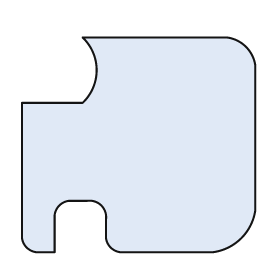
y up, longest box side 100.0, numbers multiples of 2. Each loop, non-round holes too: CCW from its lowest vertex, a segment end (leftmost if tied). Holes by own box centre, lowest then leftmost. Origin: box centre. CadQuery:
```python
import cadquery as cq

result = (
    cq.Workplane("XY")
    .moveTo(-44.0, -46.0)
    .lineTo(-36.0, -46.0)
    .lineTo(-36.0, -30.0)
    .threePointArc((-34.0, -26.0), (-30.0, -24.0))
    .lineTo(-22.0, -24.0)
    .threePointArc((-16.0, -26.0), (-14.0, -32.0))
    .lineTo(-14.0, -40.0)
    .threePointArc((-12.0, -44.0), (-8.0, -46.0))
    .lineTo(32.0, -46.0)
    .threePointArc((44.0, -40.0), (50.0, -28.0))
    .lineTo(50.0, 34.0)
    .threePointArc((46.0, 42.0), (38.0, 46.0))
    .lineTo(-24.0, 46.0)
    .threePointArc((-18.0, 32.0), (-24.0, 18.0))
    .lineTo(-50.0, 18.0)
    .lineTo(-50.0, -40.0)
    .threePointArc((-48.0, -44.0), (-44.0, -46.0))
    .close()
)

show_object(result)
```